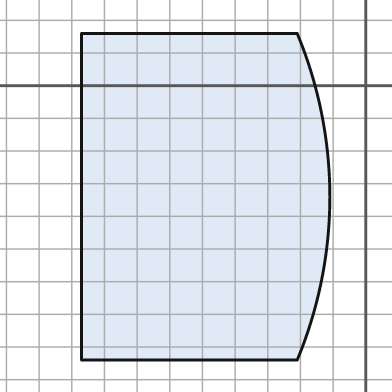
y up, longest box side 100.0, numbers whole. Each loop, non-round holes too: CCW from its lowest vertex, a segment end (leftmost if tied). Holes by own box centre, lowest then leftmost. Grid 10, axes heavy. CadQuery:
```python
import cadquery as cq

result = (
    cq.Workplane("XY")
    .moveTo(-87.0, -84.0)
    .lineTo(-21.0, -84.0)
    .threePointArc((-11.0, -34.0), (-21.0, 16.0))
    .lineTo(-87.0, 16.0)
    .close()
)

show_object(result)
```